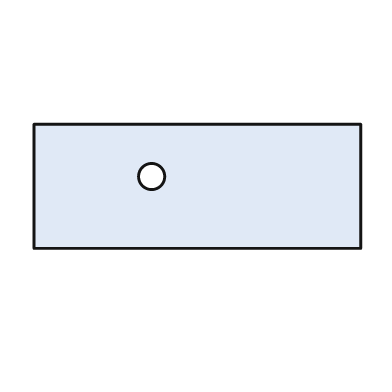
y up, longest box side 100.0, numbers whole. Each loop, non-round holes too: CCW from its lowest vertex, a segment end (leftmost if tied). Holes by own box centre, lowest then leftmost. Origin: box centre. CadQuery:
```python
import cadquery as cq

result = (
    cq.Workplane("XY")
    .moveTo(-50.0, -19.0)
    .lineTo(50.0, -19.0)
    .lineTo(50.0, 19.0)
    .lineTo(-50.0, 19.0)
    .close()
    .moveTo(-14.0, 3.0)
    .circle(4.0)
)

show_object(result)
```